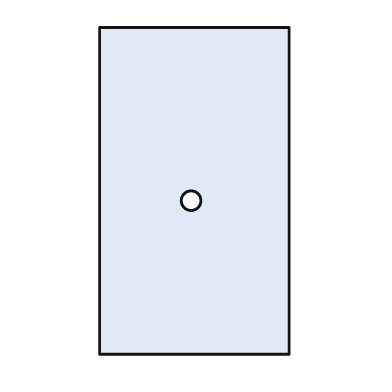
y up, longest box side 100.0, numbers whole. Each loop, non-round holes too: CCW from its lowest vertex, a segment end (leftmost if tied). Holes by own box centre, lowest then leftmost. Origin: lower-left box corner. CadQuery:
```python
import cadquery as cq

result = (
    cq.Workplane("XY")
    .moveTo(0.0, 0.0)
    .lineTo(58.0, 0.0)
    .lineTo(58.0, 100.0)
    .lineTo(0.0, 100.0)
    .close()
    .moveTo(28.0, 47.0)
    .circle(3.0)
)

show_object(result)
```